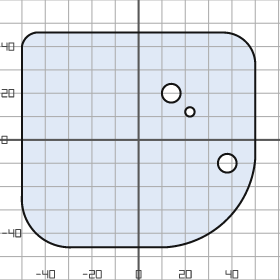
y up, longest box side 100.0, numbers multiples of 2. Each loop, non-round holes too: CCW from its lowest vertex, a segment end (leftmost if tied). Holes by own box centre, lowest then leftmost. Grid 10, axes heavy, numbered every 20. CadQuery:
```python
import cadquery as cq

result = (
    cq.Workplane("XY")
    .moveTo(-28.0, -46.0)
    .lineTo(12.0, -46.0)
    .threePointArc((38.0, -34.0), (50.0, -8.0))
    .lineTo(50.0, 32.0)
    .threePointArc((46.0, 42.0), (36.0, 46.0))
    .lineTo(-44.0, 46.0)
    .threePointArc((-48.0, 44.0), (-50.0, 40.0))
    .lineTo(-50.0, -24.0)
    .threePointArc((-44.0, -40.0), (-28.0, -46.0))
    .close()
    .moveTo(38.0, -10.0)
    .circle(4.0)
    .moveTo(22.0, 12.0)
    .circle(2.0)
    .moveTo(14.0, 20.0)
    .circle(4.0)
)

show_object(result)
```